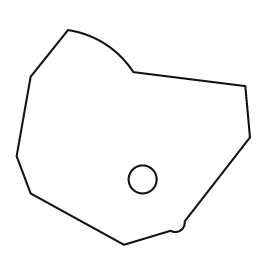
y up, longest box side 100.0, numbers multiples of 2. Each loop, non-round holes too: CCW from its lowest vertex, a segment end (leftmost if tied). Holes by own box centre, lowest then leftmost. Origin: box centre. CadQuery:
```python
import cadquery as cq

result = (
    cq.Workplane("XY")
    .moveTo(-4.0, -46.0)
    .lineTo(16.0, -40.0)
    .threePointArc((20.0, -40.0), (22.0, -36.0))
    .lineTo(50.0, 0.0)
    .lineTo(48.0, 22.0)
    .lineTo(0.0, 28.0)
    .threePointArc((-12.0, 40.0), (-28.0, 46.0))
    .lineTo(-44.0, 26.0)
    .lineTo(-50.0, -8.0)
    .lineTo(-44.0, -24.0)
    .close()
    .moveTo(4.0, -18.0)
    .circle(6.0)
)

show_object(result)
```